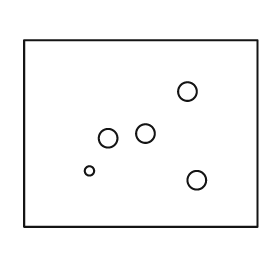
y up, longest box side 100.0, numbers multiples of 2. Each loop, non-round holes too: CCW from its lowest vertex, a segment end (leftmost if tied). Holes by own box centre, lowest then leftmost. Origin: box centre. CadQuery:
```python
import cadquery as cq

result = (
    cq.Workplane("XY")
    .moveTo(-50.0, -40.0)
    .lineTo(50.0, -40.0)
    .lineTo(50.0, 40.0)
    .lineTo(-50.0, 40.0)
    .close()
    .moveTo(24.0, -20.0)
    .circle(4.0)
    .moveTo(-22.0, -16.0)
    .circle(2.0)
    .moveTo(-14.0, -2.0)
    .circle(4.0)
    .moveTo(2.0, 0.0)
    .circle(4.0)
    .moveTo(20.0, 18.0)
    .circle(4.0)
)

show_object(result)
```